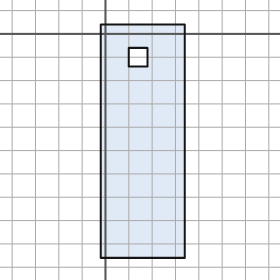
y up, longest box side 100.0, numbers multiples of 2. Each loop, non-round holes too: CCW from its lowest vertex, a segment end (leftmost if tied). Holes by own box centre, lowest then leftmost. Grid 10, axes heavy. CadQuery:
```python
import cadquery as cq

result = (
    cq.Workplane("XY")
    .moveTo(-2.0, -96.0)
    .lineTo(34.0, -96.0)
    .lineTo(34.0, 4.0)
    .lineTo(-2.0, 4.0)
    .close()
    .moveTo(10.0, -14.0)
    .lineTo(18.0, -14.0)
    .lineTo(18.0, -6.0)
    .lineTo(10.0, -6.0)
    .close()
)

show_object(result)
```